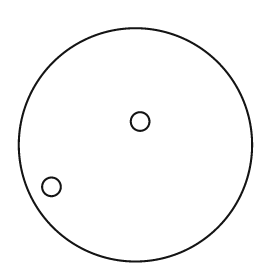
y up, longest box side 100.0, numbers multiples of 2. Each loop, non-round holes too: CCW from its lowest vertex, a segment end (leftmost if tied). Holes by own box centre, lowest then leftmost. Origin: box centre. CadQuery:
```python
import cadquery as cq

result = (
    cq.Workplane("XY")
    .moveTo(0.0, 0.0)
    .circle(50.0)
    .moveTo(-36.0, -18.0)
    .circle(4.0)
    .moveTo(2.0, 10.0)
    .circle(4.0)
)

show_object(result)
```